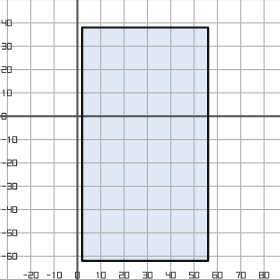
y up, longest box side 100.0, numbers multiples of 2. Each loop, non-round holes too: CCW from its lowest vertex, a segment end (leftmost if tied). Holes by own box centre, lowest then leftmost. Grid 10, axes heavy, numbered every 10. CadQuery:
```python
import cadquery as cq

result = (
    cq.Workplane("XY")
    .moveTo(2.0, -62.0)
    .lineTo(56.0, -62.0)
    .lineTo(56.0, 38.0)
    .lineTo(2.0, 38.0)
    .close()
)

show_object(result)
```